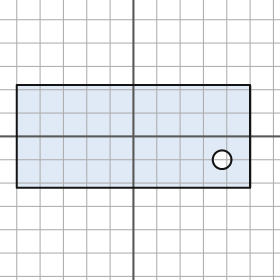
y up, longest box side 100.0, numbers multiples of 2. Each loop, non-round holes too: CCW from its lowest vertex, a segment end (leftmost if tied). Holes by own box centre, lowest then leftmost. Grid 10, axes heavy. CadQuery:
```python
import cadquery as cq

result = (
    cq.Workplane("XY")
    .moveTo(-50.0, -22.0)
    .lineTo(50.0, -22.0)
    .lineTo(50.0, 22.0)
    .lineTo(-50.0, 22.0)
    .close()
    .moveTo(38.0, -10.0)
    .circle(4.0)
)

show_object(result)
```